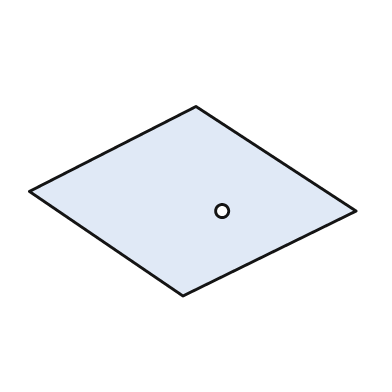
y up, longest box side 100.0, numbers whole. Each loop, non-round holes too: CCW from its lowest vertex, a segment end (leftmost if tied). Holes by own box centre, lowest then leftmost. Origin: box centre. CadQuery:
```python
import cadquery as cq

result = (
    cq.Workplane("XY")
    .moveTo(-3.0, -29.0)
    .lineTo(50.0, -3.0)
    .lineTo(1.0, 29.0)
    .lineTo(-50.0, 3.0)
    .close()
    .moveTo(9.0, -3.0)
    .circle(2.0)
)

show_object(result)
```